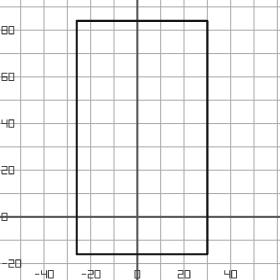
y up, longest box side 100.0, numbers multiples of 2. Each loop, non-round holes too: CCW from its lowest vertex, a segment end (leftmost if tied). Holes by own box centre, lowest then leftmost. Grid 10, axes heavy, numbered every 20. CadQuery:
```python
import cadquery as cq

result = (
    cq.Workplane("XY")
    .moveTo(-26.0, -16.0)
    .lineTo(30.0, -16.0)
    .lineTo(30.0, 84.0)
    .lineTo(-26.0, 84.0)
    .close()
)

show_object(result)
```